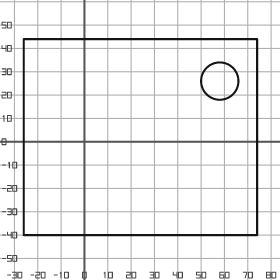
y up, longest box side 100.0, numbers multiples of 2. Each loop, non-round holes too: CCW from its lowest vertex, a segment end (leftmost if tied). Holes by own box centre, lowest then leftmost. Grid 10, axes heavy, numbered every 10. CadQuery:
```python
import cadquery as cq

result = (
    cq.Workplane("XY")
    .moveTo(-26.0, -40.0)
    .lineTo(74.0, -40.0)
    .lineTo(74.0, 44.0)
    .lineTo(-26.0, 44.0)
    .close()
    .moveTo(58.0, 26.0)
    .circle(8.0)
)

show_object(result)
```